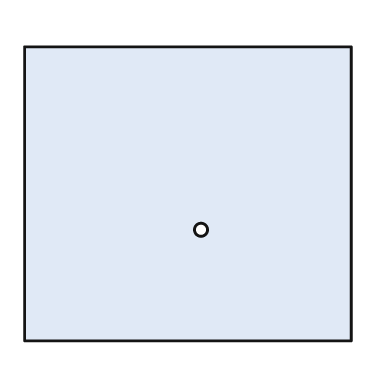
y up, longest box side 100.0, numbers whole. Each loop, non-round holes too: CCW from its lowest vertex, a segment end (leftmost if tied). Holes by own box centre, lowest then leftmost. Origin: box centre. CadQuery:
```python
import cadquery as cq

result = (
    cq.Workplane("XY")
    .moveTo(-50.0, -45.0)
    .lineTo(50.0, -45.0)
    .lineTo(50.0, 45.0)
    .lineTo(-50.0, 45.0)
    .close()
    .moveTo(4.0, -11.0)
    .circle(2.0)
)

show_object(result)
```